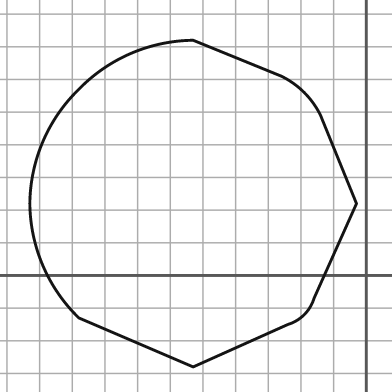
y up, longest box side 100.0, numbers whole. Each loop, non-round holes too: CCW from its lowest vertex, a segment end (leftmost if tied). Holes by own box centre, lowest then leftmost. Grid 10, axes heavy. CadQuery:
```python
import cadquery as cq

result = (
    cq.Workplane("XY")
    .moveTo(-53.0, -28.0)
    .lineTo(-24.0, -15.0)
    .threePointArc((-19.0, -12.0), (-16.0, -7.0))
    .lineTo(-3.0, 22.0)
    .lineTo(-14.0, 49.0)
    .threePointArc((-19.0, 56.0), (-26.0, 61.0))
    .lineTo(-53.0, 72.0)
    .threePointArc((-72.0, 68.0), (-88.0, 57.0))
    .threePointArc((-99.0, 41.0), (-103.0, 22.0))
    .threePointArc((-99.0, 3.0), (-88.0, -13.0))
    .close()
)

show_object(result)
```